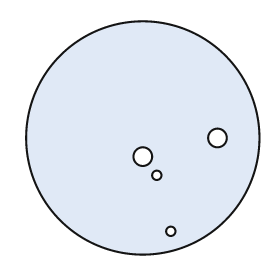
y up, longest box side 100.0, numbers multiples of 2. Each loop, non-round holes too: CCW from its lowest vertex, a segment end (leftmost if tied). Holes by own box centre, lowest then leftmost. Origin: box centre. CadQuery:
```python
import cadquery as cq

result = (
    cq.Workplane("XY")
    .moveTo(0.0, 0.0)
    .circle(50.0)
    .moveTo(12.0, -40.0)
    .circle(2.0)
    .moveTo(6.0, -16.0)
    .circle(2.0)
    .moveTo(0.0, -8.0)
    .circle(4.0)
    .moveTo(32.0, 0.0)
    .circle(4.0)
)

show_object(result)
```